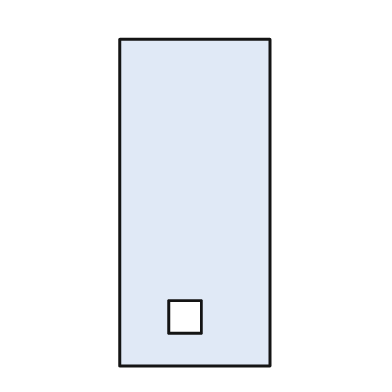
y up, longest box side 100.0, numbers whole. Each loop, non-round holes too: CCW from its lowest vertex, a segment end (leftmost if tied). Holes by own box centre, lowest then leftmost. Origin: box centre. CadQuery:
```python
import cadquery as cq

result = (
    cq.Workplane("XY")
    .moveTo(-23.0, -50.0)
    .lineTo(23.0, -50.0)
    .lineTo(23.0, 50.0)
    .lineTo(-23.0, 50.0)
    .close()
    .moveTo(-8.0, -40.0)
    .lineTo(2.0, -40.0)
    .lineTo(2.0, -30.0)
    .lineTo(-8.0, -30.0)
    .close()
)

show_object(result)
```